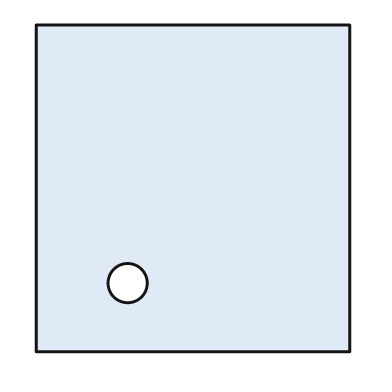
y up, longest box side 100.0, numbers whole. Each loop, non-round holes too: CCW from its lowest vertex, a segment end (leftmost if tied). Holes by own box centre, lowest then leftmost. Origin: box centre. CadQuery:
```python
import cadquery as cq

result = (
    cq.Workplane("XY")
    .moveTo(-48.0, -50.0)
    .lineTo(48.0, -50.0)
    .lineTo(48.0, 50.0)
    .lineTo(-48.0, 50.0)
    .close()
    .moveTo(-20.0, -29.0)
    .circle(6.0)
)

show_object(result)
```